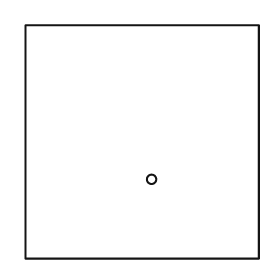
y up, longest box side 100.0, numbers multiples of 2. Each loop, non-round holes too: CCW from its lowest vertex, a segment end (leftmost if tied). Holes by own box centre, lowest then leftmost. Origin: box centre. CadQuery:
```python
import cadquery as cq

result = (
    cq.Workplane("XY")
    .moveTo(-50.0, -50.0)
    .lineTo(50.0, -50.0)
    .lineTo(50.0, 50.0)
    .lineTo(-50.0, 50.0)
    .close()
    .moveTo(4.0, -16.0)
    .circle(2.0)
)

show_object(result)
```